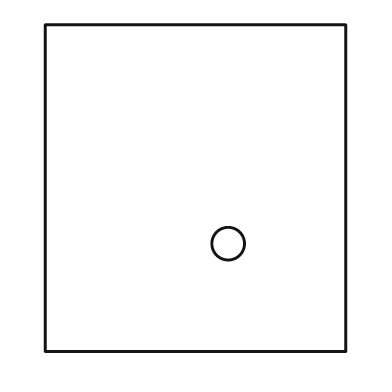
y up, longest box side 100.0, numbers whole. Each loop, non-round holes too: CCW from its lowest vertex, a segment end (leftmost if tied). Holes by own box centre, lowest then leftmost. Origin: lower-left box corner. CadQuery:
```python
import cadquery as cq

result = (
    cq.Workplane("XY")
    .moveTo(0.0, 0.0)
    .lineTo(92.0, 0.0)
    .lineTo(92.0, 100.0)
    .lineTo(0.0, 100.0)
    .close()
    .moveTo(56.0, 33.0)
    .circle(5.0)
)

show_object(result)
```